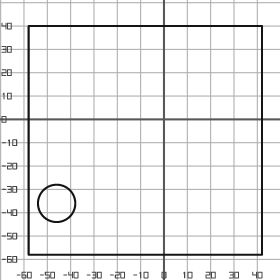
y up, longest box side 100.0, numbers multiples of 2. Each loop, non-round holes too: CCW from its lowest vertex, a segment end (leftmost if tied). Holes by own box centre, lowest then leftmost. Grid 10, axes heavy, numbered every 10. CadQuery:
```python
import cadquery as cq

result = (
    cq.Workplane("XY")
    .moveTo(-58.0, -58.0)
    .lineTo(42.0, -58.0)
    .lineTo(42.0, 40.0)
    .lineTo(-58.0, 40.0)
    .close()
    .moveTo(-46.0, -36.0)
    .circle(8.0)
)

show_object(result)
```